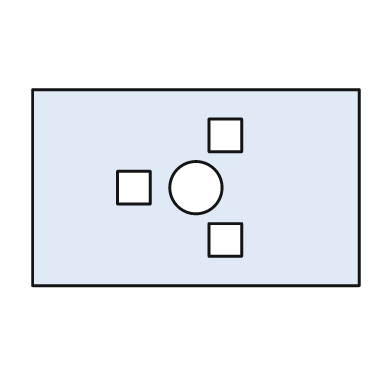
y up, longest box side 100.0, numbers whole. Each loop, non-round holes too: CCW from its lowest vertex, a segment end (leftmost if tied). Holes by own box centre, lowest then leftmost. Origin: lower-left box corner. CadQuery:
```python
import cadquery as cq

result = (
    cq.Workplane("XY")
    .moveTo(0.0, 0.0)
    .lineTo(100.0, 0.0)
    .lineTo(100.0, 60.0)
    .lineTo(0.0, 60.0)
    .close()
    .moveTo(54.0, 9.0)
    .lineTo(64.0, 9.0)
    .lineTo(64.0, 19.0)
    .lineTo(54.0, 19.0)
    .close()
    .moveTo(26.0, 25.0)
    .lineTo(36.0, 25.0)
    .lineTo(36.0, 35.0)
    .lineTo(26.0, 35.0)
    .close()
    .moveTo(50.0, 30.0)
    .circle(8.0)
    .moveTo(54.0, 41.0)
    .lineTo(64.0, 41.0)
    .lineTo(64.0, 51.0)
    .lineTo(54.0, 51.0)
    .close()
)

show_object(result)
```